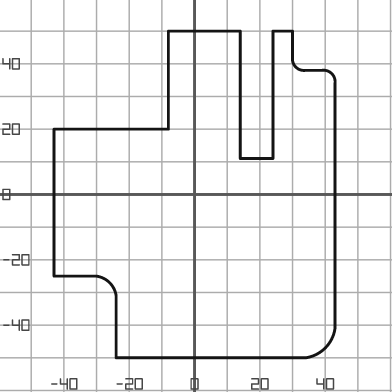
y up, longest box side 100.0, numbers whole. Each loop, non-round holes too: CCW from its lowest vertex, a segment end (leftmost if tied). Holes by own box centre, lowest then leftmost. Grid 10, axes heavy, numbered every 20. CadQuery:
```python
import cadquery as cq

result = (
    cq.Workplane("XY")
    .moveTo(-24.0, -50.0)
    .lineTo(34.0, -50.0)
    .threePointArc((40.0, -47.0), (43.0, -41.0))
    .lineTo(43.0, 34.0)
    .threePointArc((42.0, 37.0), (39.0, 38.0))
    .lineTo(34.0, 38.0)
    .threePointArc((31.0, 39.0), (30.0, 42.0))
    .lineTo(30.0, 50.0)
    .lineTo(24.0, 50.0)
    .lineTo(24.0, 11.0)
    .lineTo(14.0, 11.0)
    .lineTo(14.0, 50.0)
    .lineTo(-8.0, 50.0)
    .lineTo(-8.0, 20.0)
    .lineTo(-43.0, 20.0)
    .lineTo(-43.0, -25.0)
    .lineTo(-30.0, -25.0)
    .threePointArc((-26.0, -27.0), (-24.0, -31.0))
    .close()
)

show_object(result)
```